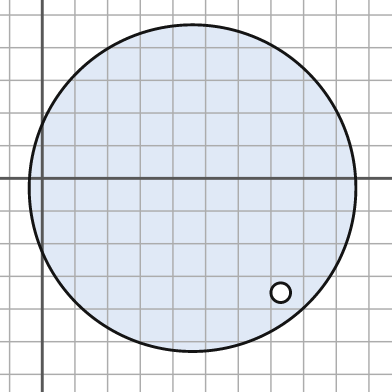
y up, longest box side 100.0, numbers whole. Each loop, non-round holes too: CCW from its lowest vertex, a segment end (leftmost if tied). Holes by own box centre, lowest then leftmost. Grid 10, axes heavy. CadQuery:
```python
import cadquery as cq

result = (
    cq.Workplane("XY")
    .moveTo(46.0, -3.0)
    .circle(50.0)
    .moveTo(73.0, -35.0)
    .circle(3.0)
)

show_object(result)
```